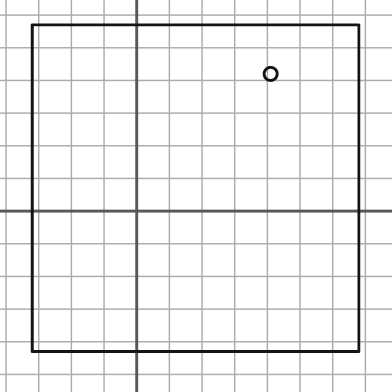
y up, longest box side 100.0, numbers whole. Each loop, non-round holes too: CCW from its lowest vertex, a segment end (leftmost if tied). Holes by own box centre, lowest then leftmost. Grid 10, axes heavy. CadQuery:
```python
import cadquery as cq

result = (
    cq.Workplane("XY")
    .moveTo(-32.0, -43.0)
    .lineTo(68.0, -43.0)
    .lineTo(68.0, 57.0)
    .lineTo(-32.0, 57.0)
    .close()
    .moveTo(41.0, 42.0)
    .circle(2.0)
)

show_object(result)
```